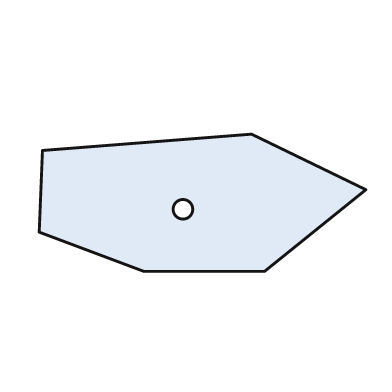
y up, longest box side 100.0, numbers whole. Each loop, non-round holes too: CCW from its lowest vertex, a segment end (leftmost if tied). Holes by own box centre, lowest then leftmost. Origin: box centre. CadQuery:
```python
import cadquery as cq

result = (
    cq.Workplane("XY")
    .moveTo(-18.0, -21.0)
    .lineTo(19.0, -21.0)
    .lineTo(50.0, 4.0)
    .lineTo(15.0, 21.0)
    .lineTo(-49.0, 16.0)
    .lineTo(-50.0, -9.0)
    .close()
    .moveTo(-6.0, -2.0)
    .circle(3.0)
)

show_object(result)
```